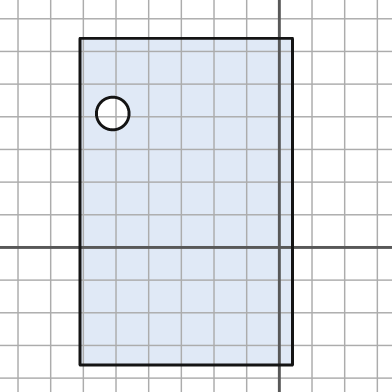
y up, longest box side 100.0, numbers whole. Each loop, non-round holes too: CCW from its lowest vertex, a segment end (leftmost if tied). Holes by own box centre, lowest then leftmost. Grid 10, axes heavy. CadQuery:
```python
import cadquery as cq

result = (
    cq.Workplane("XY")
    .moveTo(-61.0, -36.0)
    .lineTo(4.0, -36.0)
    .lineTo(4.0, 64.0)
    .lineTo(-61.0, 64.0)
    .close()
    .moveTo(-51.0, 41.0)
    .circle(5.0)
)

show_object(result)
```